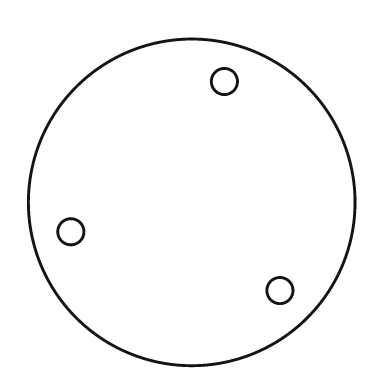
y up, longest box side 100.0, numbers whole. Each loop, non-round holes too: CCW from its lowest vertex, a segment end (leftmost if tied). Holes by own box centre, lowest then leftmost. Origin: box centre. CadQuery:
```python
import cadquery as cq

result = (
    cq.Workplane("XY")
    .moveTo(0.0, 0.0)
    .circle(50.0)
    .moveTo(27.0, -27.0)
    .circle(4.0)
    .moveTo(-37.0, -9.0)
    .circle(4.0)
    .moveTo(10.0, 37.0)
    .circle(4.0)
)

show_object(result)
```